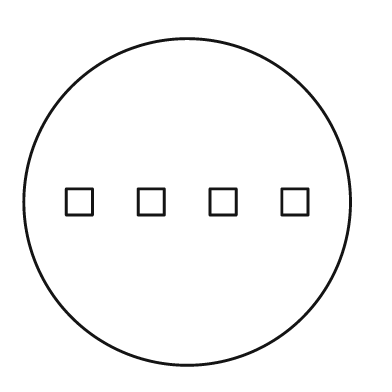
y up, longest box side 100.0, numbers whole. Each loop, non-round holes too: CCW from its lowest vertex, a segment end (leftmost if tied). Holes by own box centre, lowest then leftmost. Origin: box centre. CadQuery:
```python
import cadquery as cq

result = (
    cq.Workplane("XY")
    .moveTo(0.0, 0.0)
    .circle(50.0)
    .moveTo(-37.0, -4.0)
    .lineTo(-29.0, -4.0)
    .lineTo(-29.0, 4.0)
    .lineTo(-37.0, 4.0)
    .close()
    .moveTo(-15.0, -4.0)
    .lineTo(-7.0, -4.0)
    .lineTo(-7.0, 4.0)
    .lineTo(-15.0, 4.0)
    .close()
    .moveTo(7.0, -4.0)
    .lineTo(15.0, -4.0)
    .lineTo(15.0, 4.0)
    .lineTo(7.0, 4.0)
    .close()
    .moveTo(29.0, -4.0)
    .lineTo(37.0, -4.0)
    .lineTo(37.0, 4.0)
    .lineTo(29.0, 4.0)
    .close()
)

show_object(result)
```